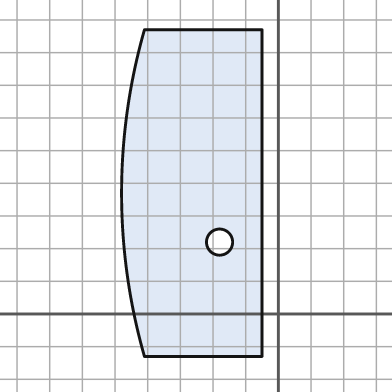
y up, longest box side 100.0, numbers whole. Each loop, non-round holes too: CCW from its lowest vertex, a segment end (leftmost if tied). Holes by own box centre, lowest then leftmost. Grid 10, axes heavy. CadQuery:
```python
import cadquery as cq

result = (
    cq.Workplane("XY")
    .moveTo(-41.0, -13.0)
    .lineTo(-5.0, -13.0)
    .lineTo(-5.0, 87.0)
    .lineTo(-41.0, 87.0)
    .threePointArc((-48.0, 37.0), (-41.0, -13.0))
    .close()
    .moveTo(-18.0, 22.0)
    .circle(4.0)
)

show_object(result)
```